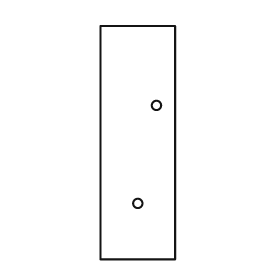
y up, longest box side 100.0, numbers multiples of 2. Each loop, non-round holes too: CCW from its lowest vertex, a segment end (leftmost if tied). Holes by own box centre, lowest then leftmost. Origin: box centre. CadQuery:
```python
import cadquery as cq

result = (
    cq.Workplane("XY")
    .moveTo(-16.0, -50.0)
    .lineTo(16.0, -50.0)
    .lineTo(16.0, 50.0)
    .lineTo(-16.0, 50.0)
    .close()
    .moveTo(0.0, -26.0)
    .circle(2.0)
    .moveTo(8.0, 16.0)
    .circle(2.0)
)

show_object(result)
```